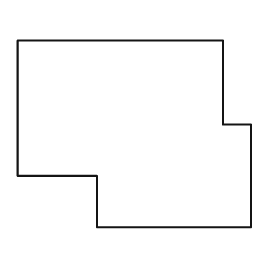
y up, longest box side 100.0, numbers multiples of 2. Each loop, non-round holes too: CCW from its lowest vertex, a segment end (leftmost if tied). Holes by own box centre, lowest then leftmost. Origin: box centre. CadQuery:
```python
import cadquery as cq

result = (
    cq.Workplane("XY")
    .moveTo(-16.0, -40.0)
    .lineTo(50.0, -40.0)
    .lineTo(50.0, 4.0)
    .lineTo(38.0, 4.0)
    .lineTo(38.0, 40.0)
    .lineTo(-50.0, 40.0)
    .lineTo(-50.0, -18.0)
    .lineTo(-16.0, -18.0)
    .close()
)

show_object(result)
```